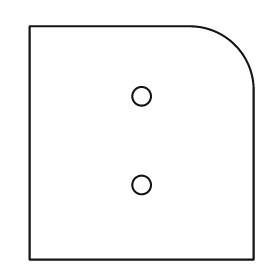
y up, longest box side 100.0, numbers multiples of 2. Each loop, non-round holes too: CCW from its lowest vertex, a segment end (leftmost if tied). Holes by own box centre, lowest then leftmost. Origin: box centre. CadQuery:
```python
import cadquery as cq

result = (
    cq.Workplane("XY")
    .moveTo(-48.0, -50.0)
    .lineTo(48.0, -50.0)
    .lineTo(48.0, 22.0)
    .threePointArc((40.0, 42.0), (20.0, 50.0))
    .lineTo(-48.0, 50.0)
    .close()
    .moveTo(0.0, -18.0)
    .circle(4.0)
    .moveTo(0.0, 20.0)
    .circle(4.0)
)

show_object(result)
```